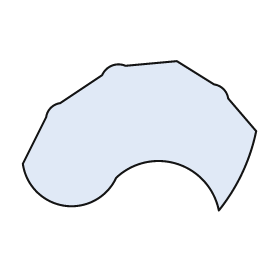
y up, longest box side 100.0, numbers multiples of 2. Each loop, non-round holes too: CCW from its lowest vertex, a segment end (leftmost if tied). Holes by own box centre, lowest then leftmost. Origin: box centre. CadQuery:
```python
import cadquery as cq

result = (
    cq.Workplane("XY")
    .moveTo(34.0, -32.0)
    .threePointArc((44.0, -16.0), (50.0, 2.0))
    .lineTo(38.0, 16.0)
    .threePointArc((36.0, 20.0), (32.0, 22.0))
    .lineTo(16.0, 32.0)
    .lineTo(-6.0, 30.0)
    .threePointArc((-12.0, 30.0), (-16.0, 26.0))
    .lineTo(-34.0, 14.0)
    .threePointArc((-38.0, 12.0), (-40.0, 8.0))
    .lineTo(-50.0, -12.0)
    .threePointArc((-32.0, -30.0), (-10.0, -18.0))
    .threePointArc((16.0, -12.0), (34.0, -32.0))
    .close()
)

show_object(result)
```